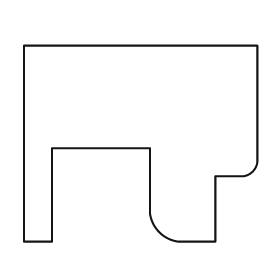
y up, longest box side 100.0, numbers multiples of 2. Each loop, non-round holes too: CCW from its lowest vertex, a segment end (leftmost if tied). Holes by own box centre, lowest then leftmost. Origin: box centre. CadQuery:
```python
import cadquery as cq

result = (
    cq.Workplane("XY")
    .moveTo(-50.0, -42.0)
    .lineTo(-38.0, -42.0)
    .lineTo(-38.0, -2.0)
    .lineTo(4.0, -2.0)
    .lineTo(4.0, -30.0)
    .threePointArc((8.0, -38.0), (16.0, -42.0))
    .lineTo(32.0, -42.0)
    .lineTo(32.0, -14.0)
    .lineTo(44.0, -14.0)
    .threePointArc((48.0, -12.0), (50.0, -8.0))
    .lineTo(50.0, 42.0)
    .lineTo(-50.0, 42.0)
    .close()
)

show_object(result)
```